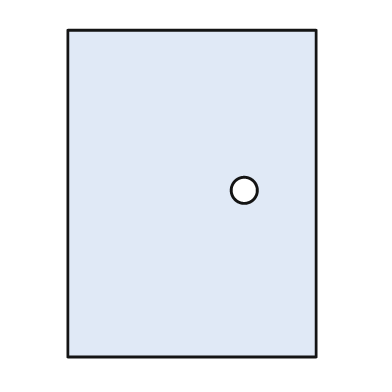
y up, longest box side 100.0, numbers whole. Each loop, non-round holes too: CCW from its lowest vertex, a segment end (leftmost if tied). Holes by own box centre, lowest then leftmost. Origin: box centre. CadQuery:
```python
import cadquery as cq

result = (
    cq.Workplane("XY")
    .moveTo(-38.0, -50.0)
    .lineTo(38.0, -50.0)
    .lineTo(38.0, 50.0)
    .lineTo(-38.0, 50.0)
    .close()
    .moveTo(16.0, 1.0)
    .circle(4.0)
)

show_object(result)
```